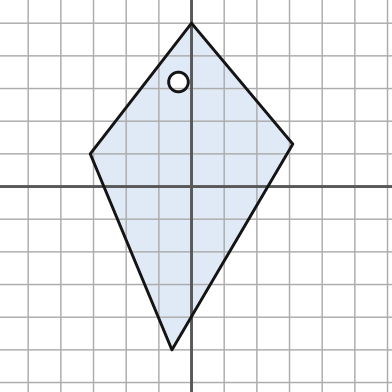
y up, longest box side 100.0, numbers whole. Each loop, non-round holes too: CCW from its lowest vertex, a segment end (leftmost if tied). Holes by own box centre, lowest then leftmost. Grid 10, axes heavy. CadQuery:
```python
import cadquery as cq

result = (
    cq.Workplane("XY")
    .moveTo(-6.0, -50.0)
    .lineTo(31.0, 13.0)
    .lineTo(0.0, 50.0)
    .lineTo(-31.0, 10.0)
    .close()
    .moveTo(-4.0, 32.0)
    .circle(3.0)
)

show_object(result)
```